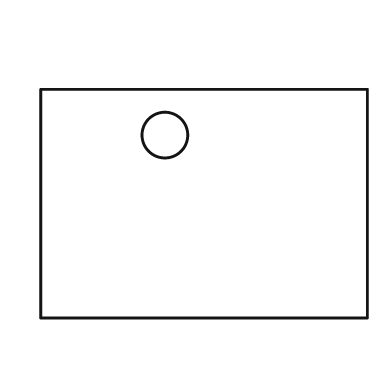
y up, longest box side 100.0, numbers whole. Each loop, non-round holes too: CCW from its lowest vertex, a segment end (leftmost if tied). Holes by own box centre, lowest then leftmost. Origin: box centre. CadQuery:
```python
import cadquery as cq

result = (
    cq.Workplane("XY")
    .moveTo(-50.0, -35.0)
    .lineTo(50.0, -35.0)
    .lineTo(50.0, 35.0)
    .lineTo(-50.0, 35.0)
    .close()
    .moveTo(-12.0, 21.0)
    .circle(7.0)
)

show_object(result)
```